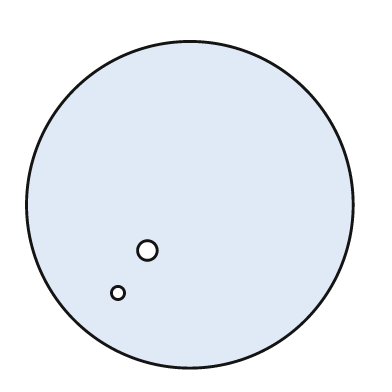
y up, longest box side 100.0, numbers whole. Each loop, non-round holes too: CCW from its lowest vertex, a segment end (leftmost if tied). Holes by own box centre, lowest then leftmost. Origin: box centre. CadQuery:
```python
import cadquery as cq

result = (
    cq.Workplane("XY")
    .moveTo(0.0, 0.0)
    .circle(50.0)
    .moveTo(-22.0, -27.0)
    .circle(2.0)
    .moveTo(-13.0, -14.0)
    .circle(3.0)
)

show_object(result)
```